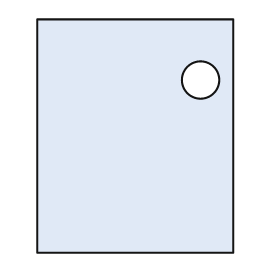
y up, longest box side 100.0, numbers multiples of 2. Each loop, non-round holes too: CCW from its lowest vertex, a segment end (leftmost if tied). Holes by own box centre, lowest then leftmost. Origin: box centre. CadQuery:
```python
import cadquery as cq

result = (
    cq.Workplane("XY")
    .moveTo(-42.0, -50.0)
    .lineTo(42.0, -50.0)
    .lineTo(42.0, 50.0)
    .lineTo(-42.0, 50.0)
    .close()
    .moveTo(28.0, 24.0)
    .circle(8.0)
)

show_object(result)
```